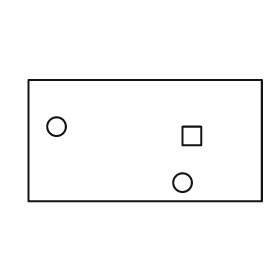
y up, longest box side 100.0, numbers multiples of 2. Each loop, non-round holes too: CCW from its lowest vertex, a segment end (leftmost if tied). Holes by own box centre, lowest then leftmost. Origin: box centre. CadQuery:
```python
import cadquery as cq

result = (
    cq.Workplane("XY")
    .moveTo(-50.0, -26.0)
    .lineTo(50.0, -26.0)
    .lineTo(50.0, 26.0)
    .lineTo(-50.0, 26.0)
    .close()
    .moveTo(16.0, -18.0)
    .circle(4.0)
    .moveTo(16.0, -2.0)
    .lineTo(24.0, -2.0)
    .lineTo(24.0, 6.0)
    .lineTo(16.0, 6.0)
    .close()
    .moveTo(-38.0, 6.0)
    .circle(4.0)
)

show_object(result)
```